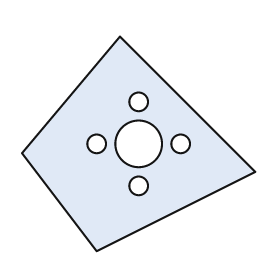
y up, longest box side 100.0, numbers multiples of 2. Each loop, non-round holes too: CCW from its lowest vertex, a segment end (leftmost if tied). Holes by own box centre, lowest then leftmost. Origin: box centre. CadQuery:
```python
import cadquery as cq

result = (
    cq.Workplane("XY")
    .moveTo(-18.0, -46.0)
    .lineTo(50.0, -12.0)
    .lineTo(-8.0, 46.0)
    .lineTo(-50.0, -4.0)
    .close()
    .moveTo(0.0, -18.0)
    .circle(4.0)
    .moveTo(-18.0, 0.0)
    .circle(4.0)
    .moveTo(0.0, 0.0)
    .circle(10.0)
    .moveTo(18.0, 0.0)
    .circle(4.0)
    .moveTo(0.0, 18.0)
    .circle(4.0)
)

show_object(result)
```